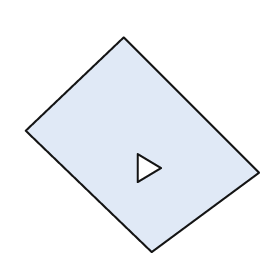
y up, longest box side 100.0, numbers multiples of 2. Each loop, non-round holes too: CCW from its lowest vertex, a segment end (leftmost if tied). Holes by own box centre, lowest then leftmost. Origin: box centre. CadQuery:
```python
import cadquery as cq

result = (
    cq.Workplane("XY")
    .moveTo(4.0, -46.0)
    .lineTo(50.0, -12.0)
    .lineTo(-8.0, 46.0)
    .lineTo(-50.0, 6.0)
    .close()
    .moveTo(-2.0, -16.0)
    .lineTo(8.0, -10.0)
    .lineTo(-2.0, -4.0)
    .close()
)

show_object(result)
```